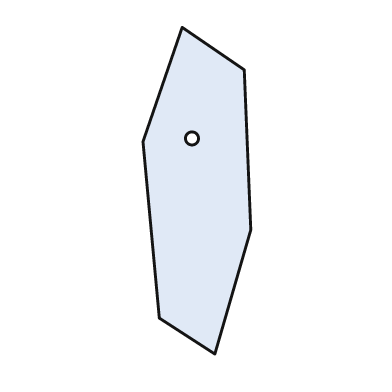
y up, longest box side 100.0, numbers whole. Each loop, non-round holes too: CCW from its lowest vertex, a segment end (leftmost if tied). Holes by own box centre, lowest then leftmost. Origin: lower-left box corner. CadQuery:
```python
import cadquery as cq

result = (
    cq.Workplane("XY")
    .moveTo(22.0, 0.0)
    .lineTo(33.0, 38.0)
    .lineTo(31.0, 87.0)
    .lineTo(12.0, 100.0)
    .lineTo(0.0, 65.0)
    .lineTo(5.0, 11.0)
    .close()
    .moveTo(15.0, 66.0)
    .circle(2.0)
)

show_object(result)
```